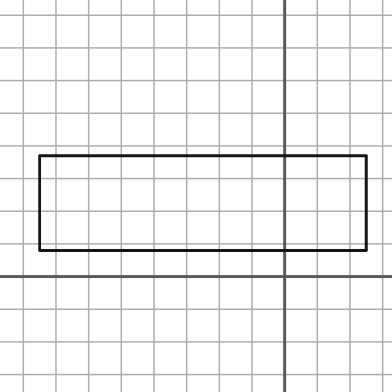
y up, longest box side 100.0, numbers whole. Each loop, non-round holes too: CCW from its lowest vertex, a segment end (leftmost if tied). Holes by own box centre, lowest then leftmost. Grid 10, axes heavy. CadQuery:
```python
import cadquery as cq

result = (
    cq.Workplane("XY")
    .moveTo(-75.0, 8.0)
    .lineTo(25.0, 8.0)
    .lineTo(25.0, 37.0)
    .lineTo(-75.0, 37.0)
    .close()
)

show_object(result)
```